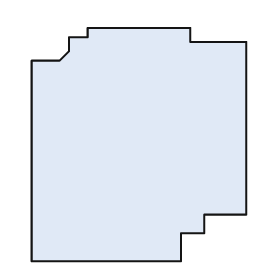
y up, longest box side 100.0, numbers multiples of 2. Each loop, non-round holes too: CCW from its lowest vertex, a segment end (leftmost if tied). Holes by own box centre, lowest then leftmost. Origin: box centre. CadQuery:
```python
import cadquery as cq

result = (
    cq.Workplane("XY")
    .moveTo(-46.0, -50.0)
    .lineTo(18.0, -50.0)
    .lineTo(18.0, -38.0)
    .lineTo(28.0, -38.0)
    .lineTo(28.0, -30.0)
    .lineTo(46.0, -30.0)
    .lineTo(46.0, 44.0)
    .lineTo(22.0, 44.0)
    .lineTo(22.0, 50.0)
    .lineTo(-22.0, 50.0)
    .lineTo(-22.0, 46.0)
    .lineTo(-30.0, 46.0)
    .lineTo(-30.0, 40.0)
    .lineTo(-34.0, 36.0)
    .lineTo(-46.0, 36.0)
    .close()
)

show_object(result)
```